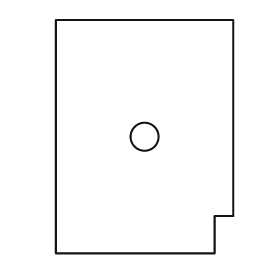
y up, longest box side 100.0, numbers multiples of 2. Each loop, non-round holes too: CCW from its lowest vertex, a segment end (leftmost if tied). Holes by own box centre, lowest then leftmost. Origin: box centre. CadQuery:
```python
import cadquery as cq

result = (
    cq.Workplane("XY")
    .moveTo(-38.0, -50.0)
    .lineTo(30.0, -50.0)
    .lineTo(30.0, -34.0)
    .lineTo(38.0, -34.0)
    .lineTo(38.0, 50.0)
    .lineTo(-38.0, 50.0)
    .close()
    .moveTo(0.0, 0.0)
    .circle(6.0)
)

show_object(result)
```